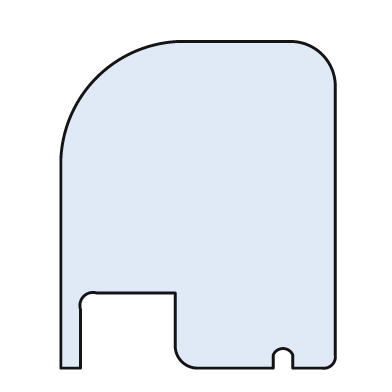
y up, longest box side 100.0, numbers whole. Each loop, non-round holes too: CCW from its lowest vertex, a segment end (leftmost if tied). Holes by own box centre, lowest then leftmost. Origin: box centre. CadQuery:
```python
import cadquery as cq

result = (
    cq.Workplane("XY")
    .moveTo(-42.0, -50.0)
    .lineTo(-36.0, -50.0)
    .lineTo(-36.0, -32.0)
    .threePointArc((-35.0, -28.0), (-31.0, -27.0))
    .lineTo(-7.0, -27.0)
    .lineTo(-7.0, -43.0)
    .threePointArc((-5.0, -48.0), (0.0, -50.0))
    .lineTo(23.0, -50.0)
    .lineTo(23.0, -46.0)
    .threePointArc((26.0, -44.0), (29.0, -46.0))
    .lineTo(29.0, -50.0)
    .lineTo(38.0, -50.0)
    .threePointArc((41.0, -49.0), (42.0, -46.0))
    .lineTo(42.0, 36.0)
    .threePointArc((38.0, 46.0), (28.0, 50.0))
    .lineTo(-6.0, 50.0)
    .threePointArc((-31.0, 39.0), (-42.0, 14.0))
    .close()
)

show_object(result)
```